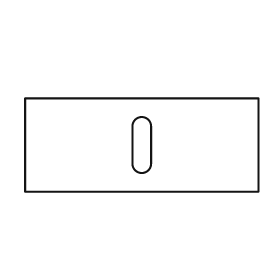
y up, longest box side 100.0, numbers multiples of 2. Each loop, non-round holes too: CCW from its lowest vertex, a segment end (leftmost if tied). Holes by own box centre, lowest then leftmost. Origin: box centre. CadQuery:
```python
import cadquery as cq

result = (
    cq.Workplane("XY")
    .moveTo(-50.0, -20.0)
    .lineTo(50.0, -20.0)
    .lineTo(50.0, 20.0)
    .lineTo(-50.0, 20.0)
    .close()
    .moveTo(-4.0, -8.0)
    .threePointArc((0.0, -12.0), (4.0, -8.0))
    .lineTo(4.0, 8.0)
    .threePointArc((0.0, 12.0), (-4.0, 8.0))
    .close()
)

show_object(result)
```